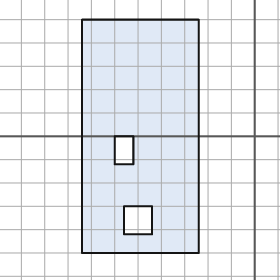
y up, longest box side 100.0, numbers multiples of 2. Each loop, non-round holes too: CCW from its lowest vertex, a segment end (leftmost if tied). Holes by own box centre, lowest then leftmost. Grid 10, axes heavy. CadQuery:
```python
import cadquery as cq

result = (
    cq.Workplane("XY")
    .moveTo(-74.0, -50.0)
    .lineTo(-24.0, -50.0)
    .lineTo(-24.0, 50.0)
    .lineTo(-74.0, 50.0)
    .close()
    .moveTo(-56.0, -42.0)
    .lineTo(-44.0, -42.0)
    .lineTo(-44.0, -30.0)
    .lineTo(-56.0, -30.0)
    .close()
    .moveTo(-60.0, -12.0)
    .lineTo(-52.0, -12.0)
    .lineTo(-52.0, 0.0)
    .lineTo(-60.0, 0.0)
    .close()
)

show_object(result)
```